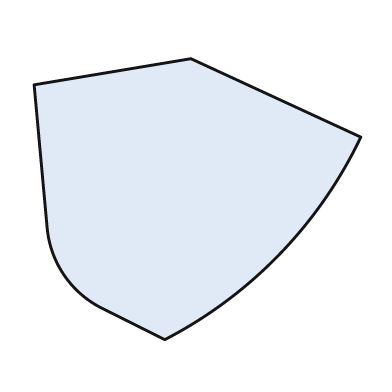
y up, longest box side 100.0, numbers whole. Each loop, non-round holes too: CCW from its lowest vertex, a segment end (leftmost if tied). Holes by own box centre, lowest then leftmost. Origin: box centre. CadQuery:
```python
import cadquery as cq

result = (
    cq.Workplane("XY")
    .moveTo(-10.0, -43.0)
    .threePointArc((25.0, -17.0), (50.0, 19.0))
    .lineTo(-2.0, 43.0)
    .lineTo(-50.0, 35.0)
    .lineTo(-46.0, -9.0)
    .threePointArc((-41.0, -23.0), (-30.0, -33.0))
    .close()
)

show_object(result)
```